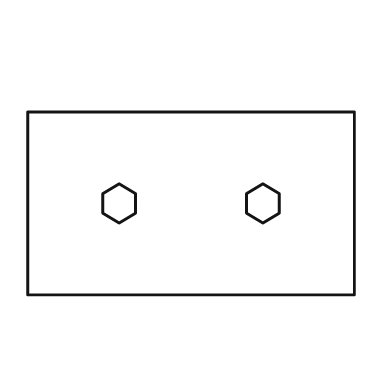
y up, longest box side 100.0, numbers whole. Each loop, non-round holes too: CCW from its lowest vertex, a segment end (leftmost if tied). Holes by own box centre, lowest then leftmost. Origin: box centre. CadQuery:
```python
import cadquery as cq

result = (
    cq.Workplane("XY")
    .moveTo(-50.0, -28.0)
    .lineTo(50.0, -28.0)
    .lineTo(50.0, 28.0)
    .lineTo(-50.0, 28.0)
    .close()
    .moveTo(-22.0, -6.0)
    .lineTo(-17.0, -3.0)
    .lineTo(-17.0, 3.0)
    .lineTo(-22.0, 6.0)
    .lineTo(-27.0, 3.0)
    .lineTo(-27.0, -3.0)
    .close()
    .moveTo(22.0, -6.0)
    .lineTo(27.0, -3.0)
    .lineTo(27.0, 3.0)
    .lineTo(22.0, 6.0)
    .lineTo(17.0, 3.0)
    .lineTo(17.0, -3.0)
    .close()
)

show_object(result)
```